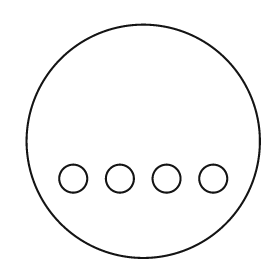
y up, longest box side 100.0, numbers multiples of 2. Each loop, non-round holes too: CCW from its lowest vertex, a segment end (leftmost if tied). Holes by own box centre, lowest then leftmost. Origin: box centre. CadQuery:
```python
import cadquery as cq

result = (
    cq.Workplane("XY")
    .moveTo(0.0, 0.0)
    .circle(50.0)
    .moveTo(-30.0, -16.0)
    .circle(6.0)
    .moveTo(-10.0, -16.0)
    .circle(6.0)
    .moveTo(10.0, -16.0)
    .circle(6.0)
    .moveTo(30.0, -16.0)
    .circle(6.0)
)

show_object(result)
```